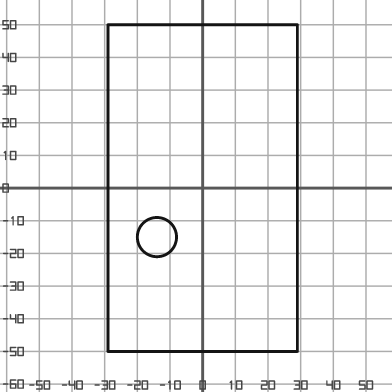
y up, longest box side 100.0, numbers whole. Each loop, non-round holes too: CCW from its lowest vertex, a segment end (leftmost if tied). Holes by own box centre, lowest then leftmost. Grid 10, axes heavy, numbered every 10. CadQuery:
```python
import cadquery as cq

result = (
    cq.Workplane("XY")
    .moveTo(-29.0, -50.0)
    .lineTo(29.0, -50.0)
    .lineTo(29.0, 50.0)
    .lineTo(-29.0, 50.0)
    .close()
    .moveTo(-14.0, -15.0)
    .circle(6.0)
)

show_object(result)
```